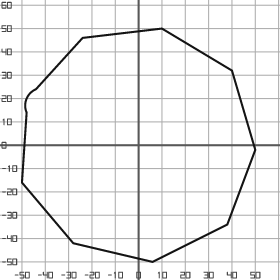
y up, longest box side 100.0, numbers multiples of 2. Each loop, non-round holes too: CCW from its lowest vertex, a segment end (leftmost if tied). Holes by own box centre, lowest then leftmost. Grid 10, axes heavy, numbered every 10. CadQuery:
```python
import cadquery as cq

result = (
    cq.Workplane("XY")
    .moveTo(6.0, -50.0)
    .lineTo(38.0, -34.0)
    .lineTo(50.0, -2.0)
    .lineTo(40.0, 32.0)
    .lineTo(10.0, 50.0)
    .lineTo(-24.0, 46.0)
    .lineTo(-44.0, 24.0)
    .threePointArc((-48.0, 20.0), (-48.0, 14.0))
    .lineTo(-50.0, -16.0)
    .lineTo(-28.0, -42.0)
    .close()
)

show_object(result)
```